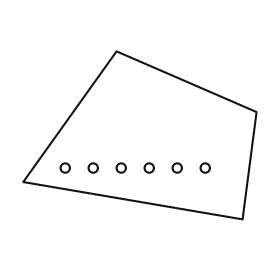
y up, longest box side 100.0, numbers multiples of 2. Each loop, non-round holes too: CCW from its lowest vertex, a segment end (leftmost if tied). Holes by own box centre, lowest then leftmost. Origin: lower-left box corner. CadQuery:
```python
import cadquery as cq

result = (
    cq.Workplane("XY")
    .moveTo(94.0, 0.0)
    .lineTo(100.0, 46.0)
    .lineTo(40.0, 72.0)
    .lineTo(0.0, 16.0)
    .close()
    .moveTo(18.0, 22.0)
    .circle(2.0)
    .moveTo(30.0, 22.0)
    .circle(2.0)
    .moveTo(42.0, 22.0)
    .circle(2.0)
    .moveTo(54.0, 22.0)
    .circle(2.0)
    .moveTo(66.0, 22.0)
    .circle(2.0)
    .moveTo(78.0, 22.0)
    .circle(2.0)
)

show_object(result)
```